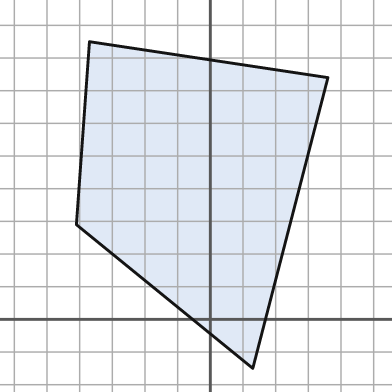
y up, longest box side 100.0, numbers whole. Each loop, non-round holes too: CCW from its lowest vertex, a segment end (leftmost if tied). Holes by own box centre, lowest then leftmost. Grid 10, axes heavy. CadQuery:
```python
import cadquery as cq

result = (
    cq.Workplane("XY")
    .moveTo(13.0, -15.0)
    .lineTo(36.0, 74.0)
    .lineTo(-37.0, 85.0)
    .lineTo(-41.0, 29.0)
    .close()
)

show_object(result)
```